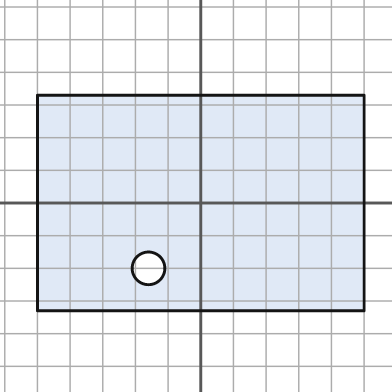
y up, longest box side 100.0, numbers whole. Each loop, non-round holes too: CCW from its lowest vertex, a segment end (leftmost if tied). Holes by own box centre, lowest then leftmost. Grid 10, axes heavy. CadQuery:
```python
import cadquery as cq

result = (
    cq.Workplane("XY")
    .moveTo(-50.0, -33.0)
    .lineTo(50.0, -33.0)
    .lineTo(50.0, 33.0)
    .lineTo(-50.0, 33.0)
    .close()
    .moveTo(-16.0, -20.0)
    .circle(5.0)
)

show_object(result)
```